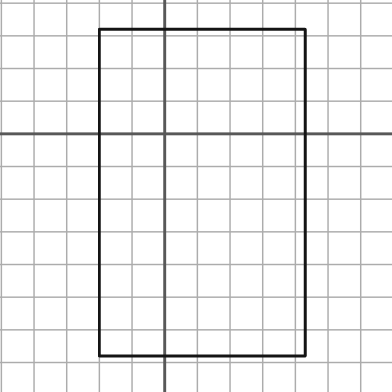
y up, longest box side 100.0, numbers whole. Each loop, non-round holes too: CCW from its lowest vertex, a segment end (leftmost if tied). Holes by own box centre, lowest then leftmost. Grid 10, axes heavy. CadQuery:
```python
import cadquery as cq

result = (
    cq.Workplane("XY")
    .moveTo(-20.0, -68.0)
    .lineTo(43.0, -68.0)
    .lineTo(43.0, 32.0)
    .lineTo(-20.0, 32.0)
    .close()
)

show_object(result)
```